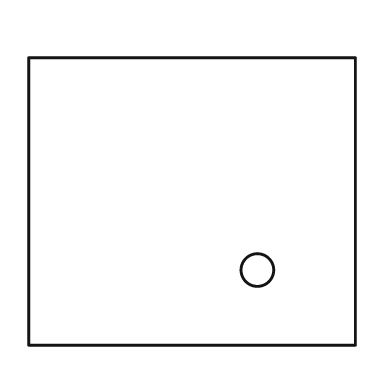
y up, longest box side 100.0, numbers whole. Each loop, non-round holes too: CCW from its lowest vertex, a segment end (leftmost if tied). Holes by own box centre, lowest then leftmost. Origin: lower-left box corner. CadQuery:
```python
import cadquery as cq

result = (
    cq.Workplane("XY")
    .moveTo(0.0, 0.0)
    .lineTo(100.0, 0.0)
    .lineTo(100.0, 88.0)
    .lineTo(0.0, 88.0)
    .close()
    .moveTo(70.0, 23.0)
    .circle(5.0)
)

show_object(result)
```